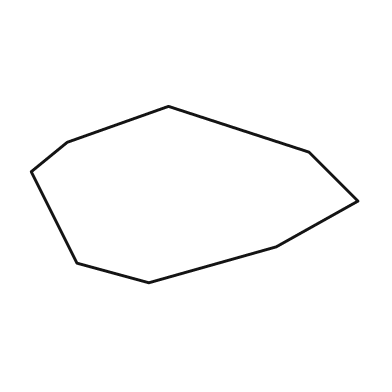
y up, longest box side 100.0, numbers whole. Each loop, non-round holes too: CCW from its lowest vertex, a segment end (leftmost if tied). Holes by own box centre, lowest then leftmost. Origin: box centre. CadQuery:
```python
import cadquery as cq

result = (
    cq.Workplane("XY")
    .moveTo(-14.0, -27.0)
    .lineTo(25.0, -16.0)
    .lineTo(50.0, -2.0)
    .lineTo(35.0, 13.0)
    .lineTo(-8.0, 27.0)
    .lineTo(-39.0, 16.0)
    .lineTo(-50.0, 7.0)
    .lineTo(-36.0, -21.0)
    .close()
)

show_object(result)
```